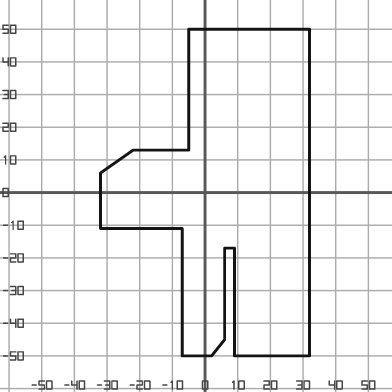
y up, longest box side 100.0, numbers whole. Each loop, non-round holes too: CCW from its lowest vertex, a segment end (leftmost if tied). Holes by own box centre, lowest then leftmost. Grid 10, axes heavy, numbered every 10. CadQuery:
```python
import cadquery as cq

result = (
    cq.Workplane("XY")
    .moveTo(-7.0, -50.0)
    .lineTo(2.0, -50.0)
    .lineTo(6.0, -45.0)
    .lineTo(6.0, -17.0)
    .lineTo(9.0, -17.0)
    .lineTo(9.0, -50.0)
    .lineTo(32.0, -50.0)
    .lineTo(32.0, 50.0)
    .lineTo(-5.0, 50.0)
    .lineTo(-5.0, 13.0)
    .lineTo(-22.0, 13.0)
    .lineTo(-32.0, 6.0)
    .lineTo(-32.0, -11.0)
    .lineTo(-7.0, -11.0)
    .close()
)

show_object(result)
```